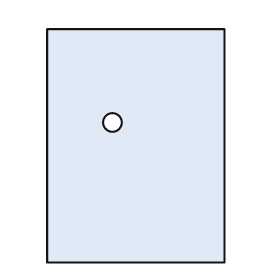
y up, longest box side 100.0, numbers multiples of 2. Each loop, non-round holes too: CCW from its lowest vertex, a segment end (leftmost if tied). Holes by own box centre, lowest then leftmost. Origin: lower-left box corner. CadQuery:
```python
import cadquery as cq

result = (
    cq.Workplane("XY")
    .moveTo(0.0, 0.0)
    .lineTo(76.0, 0.0)
    .lineTo(76.0, 100.0)
    .lineTo(0.0, 100.0)
    .close()
    .moveTo(28.0, 60.0)
    .circle(4.0)
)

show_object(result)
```